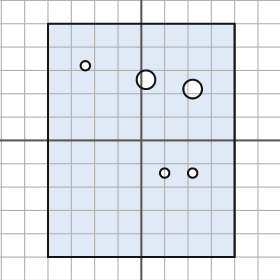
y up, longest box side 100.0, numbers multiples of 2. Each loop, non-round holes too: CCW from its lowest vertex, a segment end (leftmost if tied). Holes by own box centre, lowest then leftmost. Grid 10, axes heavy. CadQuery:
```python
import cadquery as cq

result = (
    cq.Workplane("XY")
    .moveTo(-40.0, -50.0)
    .lineTo(40.0, -50.0)
    .lineTo(40.0, 50.0)
    .lineTo(-40.0, 50.0)
    .close()
    .moveTo(10.0, -14.0)
    .circle(2.0)
    .moveTo(22.0, -14.0)
    .circle(2.0)
    .moveTo(22.0, 22.0)
    .circle(4.0)
    .moveTo(2.0, 26.0)
    .circle(4.0)
    .moveTo(-24.0, 32.0)
    .circle(2.0)
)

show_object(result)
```